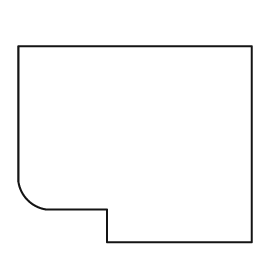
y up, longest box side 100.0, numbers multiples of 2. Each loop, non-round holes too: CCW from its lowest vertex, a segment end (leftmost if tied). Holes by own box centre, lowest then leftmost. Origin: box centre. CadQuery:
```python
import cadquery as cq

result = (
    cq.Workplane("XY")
    .moveTo(-12.0, -42.0)
    .lineTo(50.0, -42.0)
    .lineTo(50.0, 42.0)
    .lineTo(-50.0, 42.0)
    .lineTo(-50.0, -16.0)
    .threePointArc((-46.0, -24.0), (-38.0, -28.0))
    .lineTo(-12.0, -28.0)
    .close()
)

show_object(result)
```